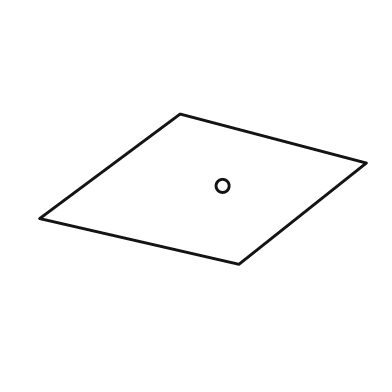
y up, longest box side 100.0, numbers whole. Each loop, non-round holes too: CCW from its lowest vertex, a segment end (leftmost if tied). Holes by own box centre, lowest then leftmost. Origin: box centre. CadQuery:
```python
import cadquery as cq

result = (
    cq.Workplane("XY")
    .moveTo(11.0, -23.0)
    .lineTo(50.0, 8.0)
    .lineTo(-7.0, 23.0)
    .lineTo(-50.0, -9.0)
    .close()
    .moveTo(6.0, 1.0)
    .circle(2.0)
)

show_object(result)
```